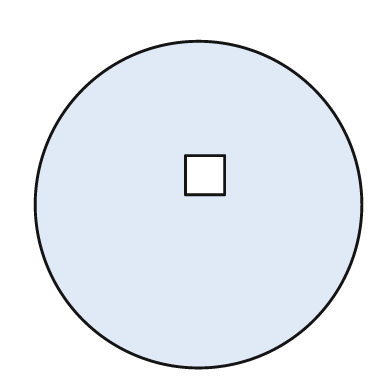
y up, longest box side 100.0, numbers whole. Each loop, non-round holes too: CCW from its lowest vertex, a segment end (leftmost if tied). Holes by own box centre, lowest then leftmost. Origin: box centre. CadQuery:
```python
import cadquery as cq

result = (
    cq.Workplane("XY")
    .moveTo(0.0, 0.0)
    .circle(50.0)
    .moveTo(-4.0, 3.0)
    .lineTo(8.0, 3.0)
    .lineTo(8.0, 15.0)
    .lineTo(-4.0, 15.0)
    .close()
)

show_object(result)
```